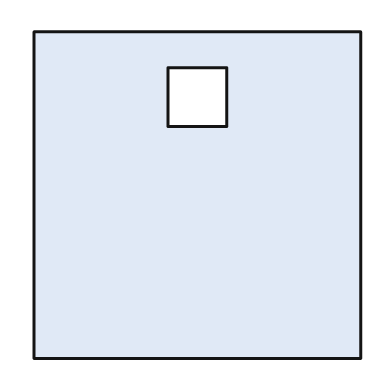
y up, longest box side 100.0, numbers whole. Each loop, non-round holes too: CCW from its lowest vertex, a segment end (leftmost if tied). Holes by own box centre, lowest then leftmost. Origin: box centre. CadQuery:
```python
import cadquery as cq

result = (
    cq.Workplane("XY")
    .moveTo(-50.0, -50.0)
    .lineTo(50.0, -50.0)
    .lineTo(50.0, 50.0)
    .lineTo(-50.0, 50.0)
    .close()
    .moveTo(-9.0, 21.0)
    .lineTo(9.0, 21.0)
    .lineTo(9.0, 39.0)
    .lineTo(-9.0, 39.0)
    .close()
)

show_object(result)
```